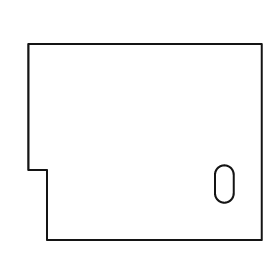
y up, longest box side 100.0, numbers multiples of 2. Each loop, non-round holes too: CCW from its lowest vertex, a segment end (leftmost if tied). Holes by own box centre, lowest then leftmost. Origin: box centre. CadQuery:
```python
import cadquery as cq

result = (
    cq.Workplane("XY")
    .moveTo(-42.0, -42.0)
    .lineTo(50.0, -42.0)
    .lineTo(50.0, 42.0)
    .lineTo(-50.0, 42.0)
    .lineTo(-50.0, -12.0)
    .lineTo(-42.0, -12.0)
    .close()
    .moveTo(30.0, -22.0)
    .threePointArc((34.0, -26.0), (38.0, -22.0))
    .lineTo(38.0, -14.0)
    .threePointArc((34.0, -10.0), (30.0, -14.0))
    .close()
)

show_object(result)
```